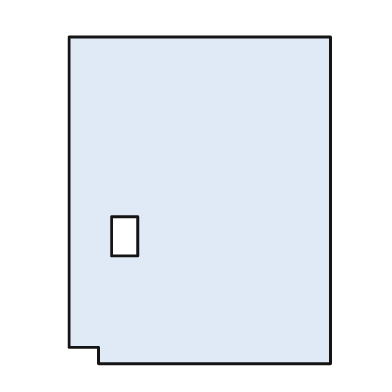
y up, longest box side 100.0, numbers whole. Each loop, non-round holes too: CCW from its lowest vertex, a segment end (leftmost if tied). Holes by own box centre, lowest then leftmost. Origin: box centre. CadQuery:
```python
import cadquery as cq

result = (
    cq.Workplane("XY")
    .moveTo(-31.0, -50.0)
    .lineTo(40.0, -50.0)
    .lineTo(40.0, 50.0)
    .lineTo(-40.0, 50.0)
    .lineTo(-40.0, -45.0)
    .lineTo(-31.0, -45.0)
    .close()
    .moveTo(-27.0, -17.0)
    .lineTo(-19.0, -17.0)
    .lineTo(-19.0, -5.0)
    .lineTo(-27.0, -5.0)
    .close()
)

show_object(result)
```